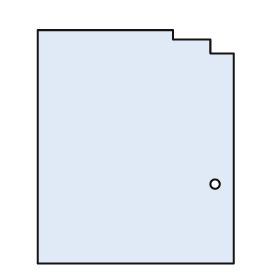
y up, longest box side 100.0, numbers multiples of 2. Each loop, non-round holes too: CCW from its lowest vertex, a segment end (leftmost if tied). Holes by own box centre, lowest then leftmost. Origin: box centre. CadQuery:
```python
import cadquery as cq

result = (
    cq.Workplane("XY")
    .moveTo(-42.0, -50.0)
    .lineTo(42.0, -50.0)
    .lineTo(42.0, 40.0)
    .lineTo(32.0, 40.0)
    .lineTo(32.0, 46.0)
    .lineTo(16.0, 46.0)
    .lineTo(16.0, 50.0)
    .lineTo(-42.0, 50.0)
    .close()
    .moveTo(34.0, -16.0)
    .circle(2.0)
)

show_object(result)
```